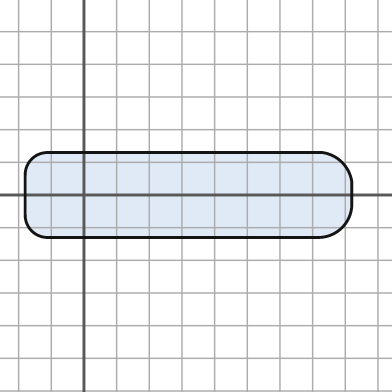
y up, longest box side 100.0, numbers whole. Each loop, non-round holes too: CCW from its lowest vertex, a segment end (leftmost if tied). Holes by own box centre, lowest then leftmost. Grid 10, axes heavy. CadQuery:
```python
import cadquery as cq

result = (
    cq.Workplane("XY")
    .moveTo(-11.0, -13.0)
    .lineTo(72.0, -13.0)
    .threePointArc((79.0, -10.0), (82.0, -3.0))
    .lineTo(82.0, 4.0)
    .threePointArc((79.0, 10.0), (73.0, 13.0))
    .lineTo(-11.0, 13.0)
    .threePointArc((-16.0, 11.0), (-18.0, 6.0))
    .lineTo(-18.0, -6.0)
    .threePointArc((-16.0, -11.0), (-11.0, -13.0))
    .close()
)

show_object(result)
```